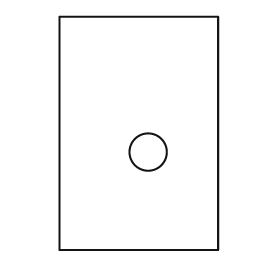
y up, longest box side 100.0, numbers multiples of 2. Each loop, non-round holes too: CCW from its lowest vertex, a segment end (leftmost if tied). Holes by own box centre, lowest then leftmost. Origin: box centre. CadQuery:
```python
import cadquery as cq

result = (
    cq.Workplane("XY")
    .moveTo(-34.0, -50.0)
    .lineTo(34.0, -50.0)
    .lineTo(34.0, 50.0)
    .lineTo(-34.0, 50.0)
    .close()
    .moveTo(4.0, -8.0)
    .circle(8.0)
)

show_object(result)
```